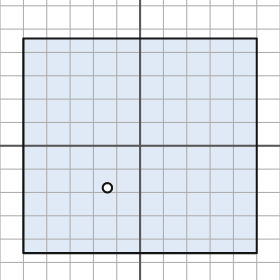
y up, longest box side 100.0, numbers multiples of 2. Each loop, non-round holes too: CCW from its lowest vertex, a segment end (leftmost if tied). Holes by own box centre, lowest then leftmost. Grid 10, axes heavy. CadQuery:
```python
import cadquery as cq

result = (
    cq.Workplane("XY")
    .moveTo(-50.0, -46.0)
    .lineTo(50.0, -46.0)
    .lineTo(50.0, 46.0)
    .lineTo(-50.0, 46.0)
    .close()
    .moveTo(-14.0, -18.0)
    .circle(2.0)
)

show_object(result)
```